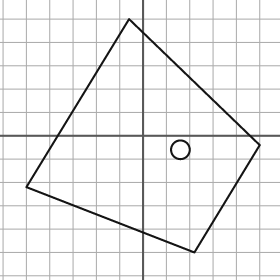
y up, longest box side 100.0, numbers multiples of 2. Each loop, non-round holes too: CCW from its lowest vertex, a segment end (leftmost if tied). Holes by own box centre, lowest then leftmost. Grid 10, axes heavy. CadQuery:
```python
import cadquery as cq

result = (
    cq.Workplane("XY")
    .moveTo(22.0, -50.0)
    .lineTo(50.0, -4.0)
    .lineTo(-6.0, 50.0)
    .lineTo(-50.0, -22.0)
    .close()
    .moveTo(16.0, -6.0)
    .circle(4.0)
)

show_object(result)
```